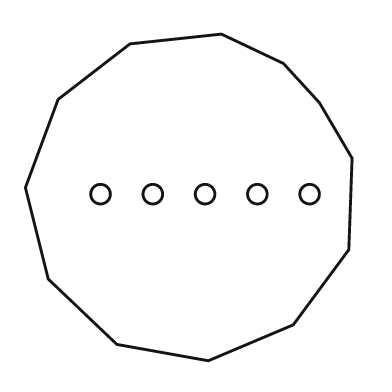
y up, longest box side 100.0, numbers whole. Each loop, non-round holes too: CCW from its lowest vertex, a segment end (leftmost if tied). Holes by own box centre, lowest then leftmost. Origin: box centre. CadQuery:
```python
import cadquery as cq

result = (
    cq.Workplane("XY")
    .moveTo(6.0, -50.0)
    .lineTo(32.0, -39.0)
    .lineTo(49.0, -16.0)
    .lineTo(50.0, 12.0)
    .lineTo(40.0, 29.0)
    .lineTo(29.0, 41.0)
    .lineTo(10.0, 50.0)
    .lineTo(-18.0, 47.0)
    .lineTo(-40.0, 30.0)
    .lineTo(-50.0, 3.0)
    .lineTo(-43.0, -25.0)
    .lineTo(-22.0, -45.0)
    .close()
    .moveTo(-27.0, 1.0)
    .circle(3.0)
    .moveTo(-11.0, 1.0)
    .circle(3.0)
    .moveTo(5.0, 1.0)
    .circle(3.0)
    .moveTo(21.0, 1.0)
    .circle(3.0)
    .moveTo(37.0, 1.0)
    .circle(3.0)
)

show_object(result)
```